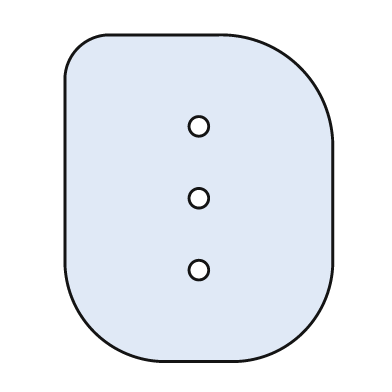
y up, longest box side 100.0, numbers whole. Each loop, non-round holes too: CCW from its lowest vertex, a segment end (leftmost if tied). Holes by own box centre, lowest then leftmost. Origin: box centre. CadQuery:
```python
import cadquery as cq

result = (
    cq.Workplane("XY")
    .moveTo(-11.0, -50.0)
    .lineTo(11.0, -50.0)
    .threePointArc((32.0, -41.0), (41.0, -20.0))
    .lineTo(41.0, 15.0)
    .threePointArc((31.0, 40.0), (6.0, 50.0))
    .lineTo(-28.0, 50.0)
    .threePointArc((-37.0, 46.0), (-41.0, 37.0))
    .lineTo(-41.0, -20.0)
    .threePointArc((-32.0, -41.0), (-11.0, -50.0))
    .close()
    .moveTo(0.0, -22.0)
    .circle(3.0)
    .moveTo(0.0, 0.0)
    .circle(3.0)
    .moveTo(0.0, 22.0)
    .circle(3.0)
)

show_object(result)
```